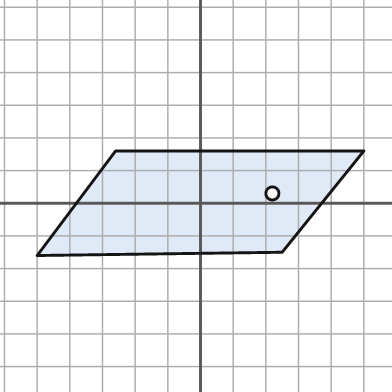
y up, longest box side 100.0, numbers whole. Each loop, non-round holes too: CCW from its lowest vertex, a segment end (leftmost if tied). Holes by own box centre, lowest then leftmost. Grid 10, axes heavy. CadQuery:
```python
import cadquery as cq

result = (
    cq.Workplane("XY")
    .moveTo(-50.0, -16.0)
    .lineTo(25.0, -15.0)
    .lineTo(50.0, 16.0)
    .lineTo(-26.0, 16.0)
    .close()
    .moveTo(22.0, 3.0)
    .circle(2.0)
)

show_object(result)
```